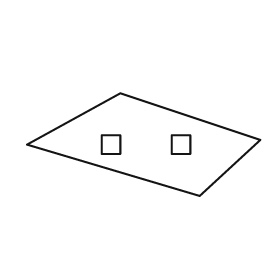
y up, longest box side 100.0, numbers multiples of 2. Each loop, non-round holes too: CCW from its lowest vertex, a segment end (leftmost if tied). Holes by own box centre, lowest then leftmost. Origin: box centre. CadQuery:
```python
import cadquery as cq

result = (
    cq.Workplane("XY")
    .moveTo(24.0, -22.0)
    .lineTo(50.0, 2.0)
    .lineTo(-10.0, 22.0)
    .lineTo(-50.0, 0.0)
    .close()
    .moveTo(-18.0, -4.0)
    .lineTo(-10.0, -4.0)
    .lineTo(-10.0, 4.0)
    .lineTo(-18.0, 4.0)
    .close()
    .moveTo(12.0, -4.0)
    .lineTo(20.0, -4.0)
    .lineTo(20.0, 4.0)
    .lineTo(12.0, 4.0)
    .close()
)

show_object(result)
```